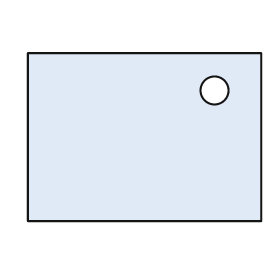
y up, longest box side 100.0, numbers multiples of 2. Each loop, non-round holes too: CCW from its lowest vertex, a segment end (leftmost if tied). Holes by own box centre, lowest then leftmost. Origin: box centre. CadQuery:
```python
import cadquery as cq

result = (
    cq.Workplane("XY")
    .moveTo(-50.0, -36.0)
    .lineTo(50.0, -36.0)
    .lineTo(50.0, 36.0)
    .lineTo(-50.0, 36.0)
    .close()
    .moveTo(30.0, 20.0)
    .circle(6.0)
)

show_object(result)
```